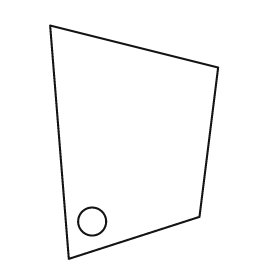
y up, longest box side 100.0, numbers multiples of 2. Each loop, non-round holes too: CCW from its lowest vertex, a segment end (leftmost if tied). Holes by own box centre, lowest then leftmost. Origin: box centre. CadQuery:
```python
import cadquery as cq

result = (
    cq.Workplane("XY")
    .moveTo(-28.0, -50.0)
    .lineTo(28.0, -32.0)
    .lineTo(36.0, 32.0)
    .lineTo(-36.0, 50.0)
    .close()
    .moveTo(-18.0, -34.0)
    .circle(6.0)
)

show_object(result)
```